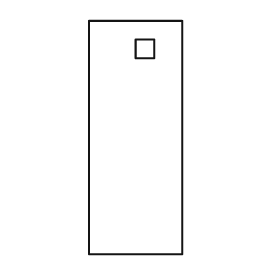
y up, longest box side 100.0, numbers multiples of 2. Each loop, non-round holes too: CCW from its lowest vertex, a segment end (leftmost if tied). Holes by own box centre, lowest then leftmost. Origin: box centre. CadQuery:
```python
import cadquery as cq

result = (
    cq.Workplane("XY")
    .moveTo(-20.0, -50.0)
    .lineTo(20.0, -50.0)
    .lineTo(20.0, 50.0)
    .lineTo(-20.0, 50.0)
    .close()
    .moveTo(0.0, 34.0)
    .lineTo(8.0, 34.0)
    .lineTo(8.0, 42.0)
    .lineTo(0.0, 42.0)
    .close()
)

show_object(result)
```